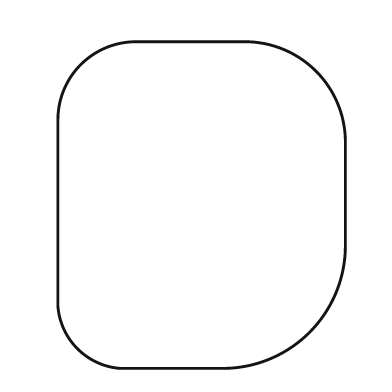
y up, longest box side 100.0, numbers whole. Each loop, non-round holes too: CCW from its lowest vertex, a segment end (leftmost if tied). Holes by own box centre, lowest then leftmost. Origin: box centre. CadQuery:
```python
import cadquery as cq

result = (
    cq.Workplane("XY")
    .moveTo(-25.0, -50.0)
    .lineTo(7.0, -50.0)
    .threePointArc((33.0, -39.0), (44.0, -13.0))
    .lineTo(44.0, 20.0)
    .threePointArc((35.0, 41.0), (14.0, 50.0))
    .lineTo(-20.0, 50.0)
    .threePointArc((-37.0, 43.0), (-44.0, 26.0))
    .lineTo(-44.0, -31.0)
    .threePointArc((-38.0, -44.0), (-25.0, -50.0))
    .close()
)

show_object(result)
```